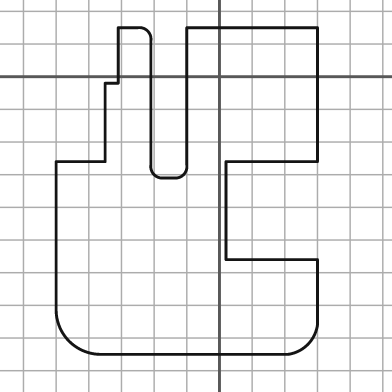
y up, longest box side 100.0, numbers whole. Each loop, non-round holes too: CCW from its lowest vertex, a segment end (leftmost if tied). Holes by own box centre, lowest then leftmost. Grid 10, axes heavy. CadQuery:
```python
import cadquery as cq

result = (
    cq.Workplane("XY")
    .moveTo(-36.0, -85.0)
    .lineTo(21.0, -85.0)
    .threePointArc((27.0, -82.0), (30.0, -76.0))
    .lineTo(30.0, -56.0)
    .lineTo(2.0, -56.0)
    .lineTo(2.0, -26.0)
    .lineTo(30.0, -26.0)
    .lineTo(30.0, 15.0)
    .lineTo(-10.0, 15.0)
    .lineTo(-10.0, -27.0)
    .threePointArc((-11.0, -30.0), (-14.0, -31.0))
    .lineTo(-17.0, -31.0)
    .threePointArc((-20.0, -30.0), (-21.0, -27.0))
    .lineTo(-21.0, 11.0)
    .threePointArc((-22.0, 14.0), (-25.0, 15.0))
    .lineTo(-31.0, 15.0)
    .lineTo(-31.0, -2.0)
    .lineTo(-35.0, -2.0)
    .lineTo(-35.0, -26.0)
    .lineTo(-50.0, -26.0)
    .lineTo(-50.0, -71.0)
    .threePointArc((-46.0, -81.0), (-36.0, -85.0))
    .close()
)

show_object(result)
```